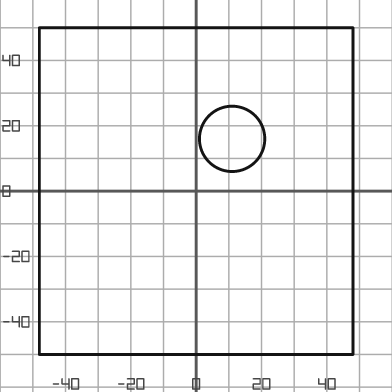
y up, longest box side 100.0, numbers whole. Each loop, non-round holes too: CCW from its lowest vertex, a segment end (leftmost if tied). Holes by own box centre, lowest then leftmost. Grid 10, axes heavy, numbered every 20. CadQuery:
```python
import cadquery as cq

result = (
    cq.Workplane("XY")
    .moveTo(-48.0, -50.0)
    .lineTo(48.0, -50.0)
    .lineTo(48.0, 50.0)
    .lineTo(-48.0, 50.0)
    .close()
    .moveTo(11.0, 16.0)
    .circle(10.0)
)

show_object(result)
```